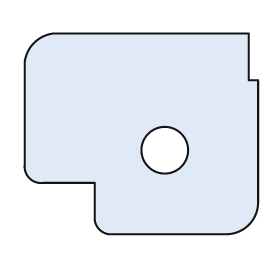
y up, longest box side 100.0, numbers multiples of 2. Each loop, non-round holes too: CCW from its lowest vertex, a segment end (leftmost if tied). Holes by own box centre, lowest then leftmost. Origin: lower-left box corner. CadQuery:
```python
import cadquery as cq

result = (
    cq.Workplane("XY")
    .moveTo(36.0, 0.0)
    .lineTo(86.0, 0.0)
    .threePointArc((96.0, 4.0), (100.0, 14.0))
    .lineTo(100.0, 66.0)
    .lineTo(96.0, 66.0)
    .lineTo(96.0, 86.0)
    .lineTo(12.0, 86.0)
    .threePointArc((4.0, 82.0), (0.0, 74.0))
    .lineTo(0.0, 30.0)
    .threePointArc((2.0, 24.0), (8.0, 22.0))
    .lineTo(30.0, 22.0)
    .lineTo(30.0, 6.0)
    .threePointArc((32.0, 2.0), (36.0, 0.0))
    .close()
    .moveTo(60.0, 36.0)
    .circle(10.0)
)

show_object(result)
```